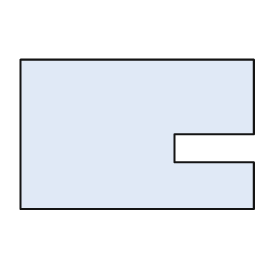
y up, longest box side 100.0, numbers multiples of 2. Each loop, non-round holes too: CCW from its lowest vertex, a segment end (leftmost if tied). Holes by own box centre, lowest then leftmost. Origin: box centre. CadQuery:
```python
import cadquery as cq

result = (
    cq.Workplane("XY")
    .moveTo(-50.0, -32.0)
    .lineTo(50.0, -32.0)
    .lineTo(50.0, -12.0)
    .lineTo(16.0, -12.0)
    .lineTo(16.0, 0.0)
    .lineTo(50.0, 0.0)
    .lineTo(50.0, 32.0)
    .lineTo(-50.0, 32.0)
    .close()
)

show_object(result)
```